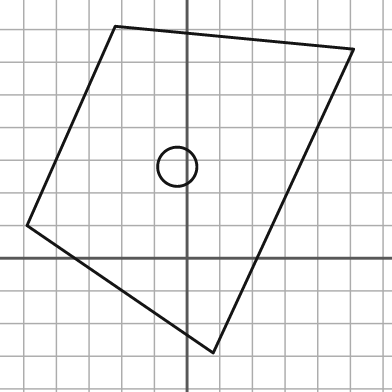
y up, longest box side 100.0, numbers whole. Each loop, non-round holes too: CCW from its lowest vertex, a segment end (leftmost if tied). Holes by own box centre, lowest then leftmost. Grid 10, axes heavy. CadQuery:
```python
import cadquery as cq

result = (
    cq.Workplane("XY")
    .moveTo(8.0, -29.0)
    .lineTo(51.0, 64.0)
    .lineTo(-22.0, 71.0)
    .lineTo(-49.0, 10.0)
    .close()
    .moveTo(-3.0, 28.0)
    .circle(6.0)
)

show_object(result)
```